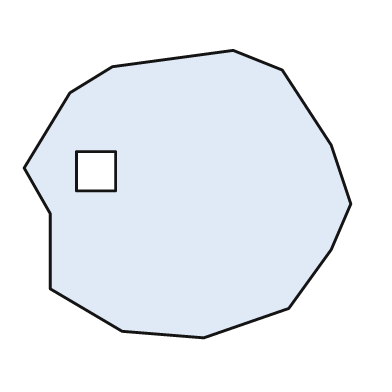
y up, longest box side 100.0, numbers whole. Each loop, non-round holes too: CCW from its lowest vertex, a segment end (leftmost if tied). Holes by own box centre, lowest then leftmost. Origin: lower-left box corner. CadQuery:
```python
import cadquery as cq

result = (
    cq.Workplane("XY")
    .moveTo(55.0, 0.0)
    .lineTo(81.0, 9.0)
    .lineTo(94.0, 27.0)
    .lineTo(100.0, 41.0)
    .lineTo(94.0, 59.0)
    .lineTo(79.0, 82.0)
    .lineTo(64.0, 88.0)
    .lineTo(27.0, 83.0)
    .lineTo(14.0, 75.0)
    .lineTo(0.0, 52.0)
    .lineTo(8.0, 38.0)
    .lineTo(8.0, 15.0)
    .lineTo(30.0, 2.0)
    .close()
    .moveTo(16.0, 45.0)
    .lineTo(28.0, 45.0)
    .lineTo(28.0, 57.0)
    .lineTo(16.0, 57.0)
    .close()
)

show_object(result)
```